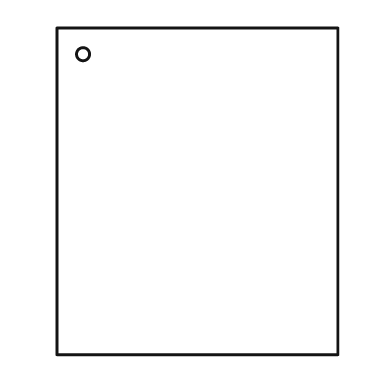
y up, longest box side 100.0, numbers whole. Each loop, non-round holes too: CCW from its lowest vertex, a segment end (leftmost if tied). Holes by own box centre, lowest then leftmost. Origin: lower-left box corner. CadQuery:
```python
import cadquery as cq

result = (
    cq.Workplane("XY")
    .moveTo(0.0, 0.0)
    .lineTo(86.0, 0.0)
    .lineTo(86.0, 100.0)
    .lineTo(0.0, 100.0)
    .close()
    .moveTo(8.0, 92.0)
    .circle(2.0)
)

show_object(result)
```